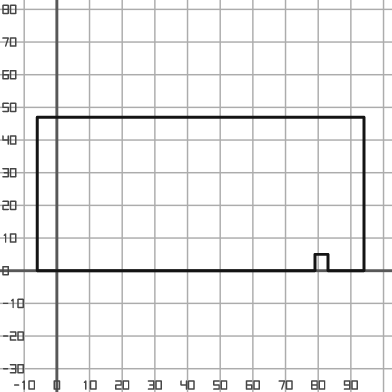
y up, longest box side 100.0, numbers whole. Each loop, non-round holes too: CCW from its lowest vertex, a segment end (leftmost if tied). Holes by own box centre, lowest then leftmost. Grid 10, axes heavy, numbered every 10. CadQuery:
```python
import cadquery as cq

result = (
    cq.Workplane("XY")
    .moveTo(-6.0, 0.0)
    .lineTo(79.0, 0.0)
    .lineTo(79.0, 5.0)
    .lineTo(83.0, 5.0)
    .lineTo(83.0, 0.0)
    .lineTo(94.0, 0.0)
    .lineTo(94.0, 47.0)
    .lineTo(-6.0, 47.0)
    .close()
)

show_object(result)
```